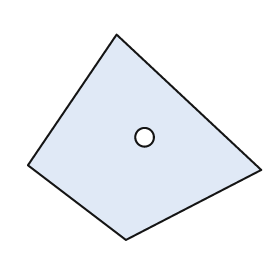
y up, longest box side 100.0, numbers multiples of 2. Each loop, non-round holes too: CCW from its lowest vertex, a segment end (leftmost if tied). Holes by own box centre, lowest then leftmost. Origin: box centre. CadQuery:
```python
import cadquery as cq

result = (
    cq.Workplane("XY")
    .moveTo(-8.0, -44.0)
    .lineTo(50.0, -14.0)
    .lineTo(-12.0, 44.0)
    .lineTo(-50.0, -12.0)
    .close()
    .moveTo(0.0, 0.0)
    .circle(4.0)
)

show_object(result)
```